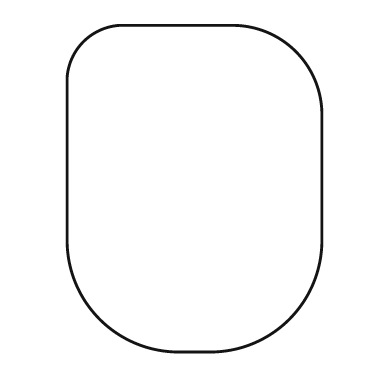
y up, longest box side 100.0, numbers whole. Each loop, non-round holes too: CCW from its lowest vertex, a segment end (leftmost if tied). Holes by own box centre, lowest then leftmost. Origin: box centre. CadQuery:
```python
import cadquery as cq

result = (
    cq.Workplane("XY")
    .moveTo(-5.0, -50.0)
    .lineTo(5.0, -50.0)
    .threePointArc((29.0, -40.0), (39.0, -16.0))
    .lineTo(39.0, 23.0)
    .threePointArc((31.0, 42.0), (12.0, 50.0))
    .lineTo(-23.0, 50.0)
    .threePointArc((-34.0, 45.0), (-39.0, 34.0))
    .lineTo(-39.0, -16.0)
    .threePointArc((-29.0, -40.0), (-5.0, -50.0))
    .close()
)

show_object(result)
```